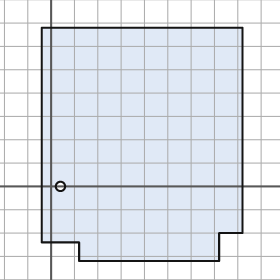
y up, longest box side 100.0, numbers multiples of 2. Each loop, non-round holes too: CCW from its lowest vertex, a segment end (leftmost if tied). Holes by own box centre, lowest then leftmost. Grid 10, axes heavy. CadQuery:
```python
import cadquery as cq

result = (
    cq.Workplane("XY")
    .moveTo(12.0, -32.0)
    .lineTo(72.0, -32.0)
    .lineTo(72.0, -20.0)
    .lineTo(82.0, -20.0)
    .lineTo(82.0, 68.0)
    .lineTo(-4.0, 68.0)
    .lineTo(-4.0, -24.0)
    .lineTo(12.0, -24.0)
    .close()
    .moveTo(4.0, 0.0)
    .circle(2.0)
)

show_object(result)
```